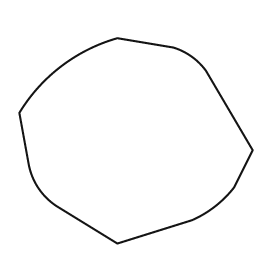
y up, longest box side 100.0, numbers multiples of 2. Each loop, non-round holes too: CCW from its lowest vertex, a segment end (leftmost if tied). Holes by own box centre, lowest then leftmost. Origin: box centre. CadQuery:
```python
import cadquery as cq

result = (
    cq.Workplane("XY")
    .moveTo(-8.0, -44.0)
    .lineTo(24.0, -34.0)
    .threePointArc((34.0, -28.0), (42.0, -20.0))
    .lineTo(50.0, -4.0)
    .lineTo(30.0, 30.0)
    .threePointArc((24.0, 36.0), (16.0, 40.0))
    .lineTo(-8.0, 44.0)
    .threePointArc((-32.0, 32.0), (-50.0, 12.0))
    .lineTo(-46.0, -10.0)
    .threePointArc((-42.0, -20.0), (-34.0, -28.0))
    .close()
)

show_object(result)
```